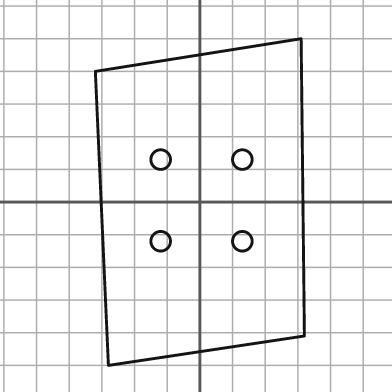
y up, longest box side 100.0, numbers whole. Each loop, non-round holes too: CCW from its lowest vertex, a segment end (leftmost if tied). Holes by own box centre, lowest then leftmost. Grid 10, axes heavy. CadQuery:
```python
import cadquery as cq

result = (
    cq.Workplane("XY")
    .moveTo(-28.0, -50.0)
    .lineTo(32.0, -41.0)
    .lineTo(31.0, 50.0)
    .lineTo(-32.0, 40.0)
    .close()
    .moveTo(-12.0, -12.0)
    .circle(3.0)
    .moveTo(13.0, -12.0)
    .circle(3.0)
    .moveTo(-12.0, 13.0)
    .circle(3.0)
    .moveTo(13.0, 13.0)
    .circle(3.0)
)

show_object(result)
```